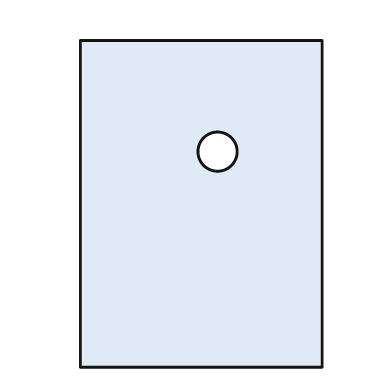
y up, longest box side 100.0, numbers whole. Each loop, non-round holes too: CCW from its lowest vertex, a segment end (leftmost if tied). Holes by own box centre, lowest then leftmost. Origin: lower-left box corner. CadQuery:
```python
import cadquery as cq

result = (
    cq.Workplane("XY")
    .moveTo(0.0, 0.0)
    .lineTo(74.0, 0.0)
    .lineTo(74.0, 100.0)
    .lineTo(0.0, 100.0)
    .close()
    .moveTo(42.0, 66.0)
    .circle(6.0)
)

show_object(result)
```